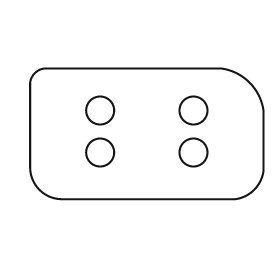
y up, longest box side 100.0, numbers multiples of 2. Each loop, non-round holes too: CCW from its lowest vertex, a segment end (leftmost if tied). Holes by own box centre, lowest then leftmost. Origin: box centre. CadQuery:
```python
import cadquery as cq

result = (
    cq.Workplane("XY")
    .moveTo(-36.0, -28.0)
    .lineTo(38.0, -28.0)
    .threePointArc((46.0, -24.0), (50.0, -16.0))
    .lineTo(50.0, 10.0)
    .threePointArc((44.0, 22.0), (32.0, 28.0))
    .lineTo(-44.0, 28.0)
    .threePointArc((-48.0, 26.0), (-50.0, 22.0))
    .lineTo(-50.0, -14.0)
    .threePointArc((-46.0, -24.0), (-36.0, -28.0))
    .close()
    .moveTo(-20.0, -8.0)
    .circle(6.0)
    .moveTo(20.0, -8.0)
    .circle(6.0)
    .moveTo(-20.0, 10.0)
    .circle(6.0)
    .moveTo(20.0, 10.0)
    .circle(6.0)
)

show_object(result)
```